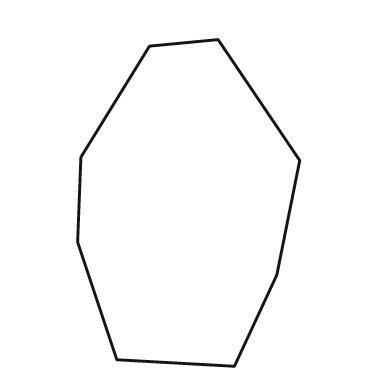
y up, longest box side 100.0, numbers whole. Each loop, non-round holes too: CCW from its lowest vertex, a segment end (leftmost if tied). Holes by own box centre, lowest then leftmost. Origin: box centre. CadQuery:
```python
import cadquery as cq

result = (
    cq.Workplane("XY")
    .moveTo(14.0, -50.0)
    .lineTo(27.0, -22.0)
    .lineTo(34.0, 13.0)
    .lineTo(9.0, 50.0)
    .lineTo(-12.0, 48.0)
    .lineTo(-33.0, 14.0)
    .lineTo(-34.0, -12.0)
    .lineTo(-22.0, -48.0)
    .close()
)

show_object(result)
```